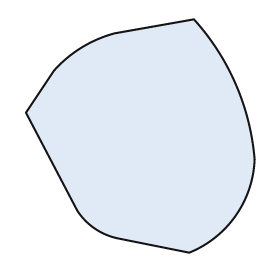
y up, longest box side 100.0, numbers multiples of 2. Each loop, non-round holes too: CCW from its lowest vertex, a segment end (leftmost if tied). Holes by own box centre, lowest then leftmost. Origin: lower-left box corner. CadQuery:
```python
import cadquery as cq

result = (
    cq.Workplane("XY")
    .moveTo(70.0, 0.0)
    .threePointArc((90.0, 16.0), (98.0, 40.0))
    .threePointArc((90.0, 72.0), (72.0, 100.0))
    .lineTo(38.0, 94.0)
    .threePointArc((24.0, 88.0), (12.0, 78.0))
    .lineTo(0.0, 60.0)
    .lineTo(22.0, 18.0)
    .threePointArc((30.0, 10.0), (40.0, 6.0))
    .close()
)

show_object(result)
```